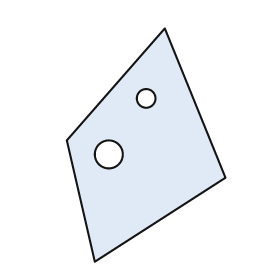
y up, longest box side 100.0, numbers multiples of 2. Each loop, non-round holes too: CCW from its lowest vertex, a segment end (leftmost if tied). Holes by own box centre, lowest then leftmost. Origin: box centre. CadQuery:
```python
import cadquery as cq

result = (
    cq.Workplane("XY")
    .moveTo(-22.0, -50.0)
    .lineTo(34.0, -14.0)
    .lineTo(8.0, 50.0)
    .lineTo(-34.0, 2.0)
    .close()
    .moveTo(-16.0, -4.0)
    .circle(6.0)
    .moveTo(0.0, 20.0)
    .circle(4.0)
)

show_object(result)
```